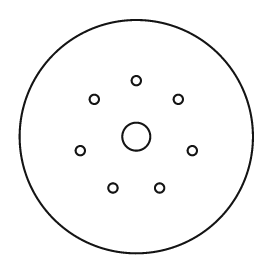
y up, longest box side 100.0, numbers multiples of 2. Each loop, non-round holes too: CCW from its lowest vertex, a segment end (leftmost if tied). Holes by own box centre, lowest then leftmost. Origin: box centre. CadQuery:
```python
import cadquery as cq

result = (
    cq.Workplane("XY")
    .moveTo(0.0, 0.0)
    .circle(50.0)
    .moveTo(-10.0, -22.0)
    .circle(2.0)
    .moveTo(10.0, -22.0)
    .circle(2.0)
    .moveTo(-24.0, -6.0)
    .circle(2.0)
    .moveTo(24.0, -6.0)
    .circle(2.0)
    .moveTo(0.0, 0.0)
    .circle(6.0)
    .moveTo(-18.0, 16.0)
    .circle(2.0)
    .moveTo(18.0, 16.0)
    .circle(2.0)
    .moveTo(0.0, 24.0)
    .circle(2.0)
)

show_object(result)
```